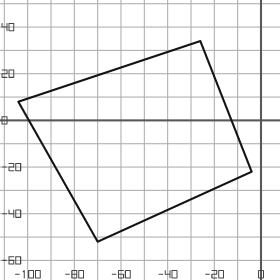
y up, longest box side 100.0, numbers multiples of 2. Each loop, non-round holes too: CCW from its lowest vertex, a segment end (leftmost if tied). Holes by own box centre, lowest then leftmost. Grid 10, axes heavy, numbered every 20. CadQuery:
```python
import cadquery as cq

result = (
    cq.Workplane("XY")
    .moveTo(-70.0, -52.0)
    .lineTo(-4.0, -22.0)
    .lineTo(-26.0, 34.0)
    .lineTo(-104.0, 8.0)
    .close()
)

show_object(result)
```